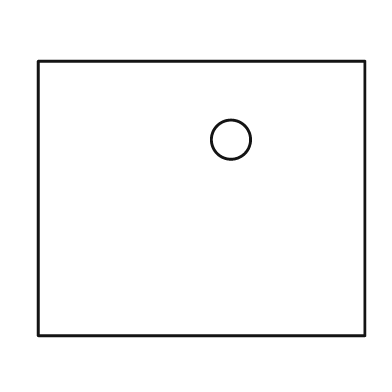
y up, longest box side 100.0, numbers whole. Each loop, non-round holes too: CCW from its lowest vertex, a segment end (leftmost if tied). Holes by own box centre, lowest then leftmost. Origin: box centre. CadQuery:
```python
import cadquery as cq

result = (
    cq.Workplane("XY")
    .moveTo(-50.0, -42.0)
    .lineTo(50.0, -42.0)
    .lineTo(50.0, 42.0)
    .lineTo(-50.0, 42.0)
    .close()
    .moveTo(9.0, 18.0)
    .circle(6.0)
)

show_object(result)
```